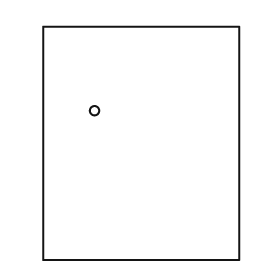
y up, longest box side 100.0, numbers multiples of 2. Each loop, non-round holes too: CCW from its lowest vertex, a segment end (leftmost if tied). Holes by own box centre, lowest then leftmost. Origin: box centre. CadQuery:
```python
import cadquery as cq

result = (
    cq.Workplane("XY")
    .moveTo(-42.0, -50.0)
    .lineTo(42.0, -50.0)
    .lineTo(42.0, 50.0)
    .lineTo(-42.0, 50.0)
    .close()
    .moveTo(-20.0, 14.0)
    .circle(2.0)
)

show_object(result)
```